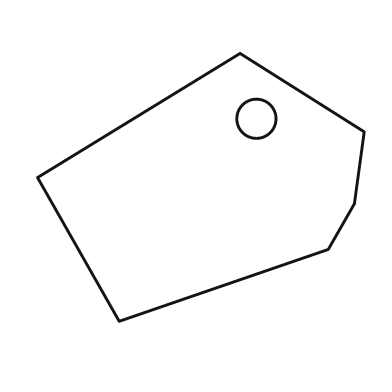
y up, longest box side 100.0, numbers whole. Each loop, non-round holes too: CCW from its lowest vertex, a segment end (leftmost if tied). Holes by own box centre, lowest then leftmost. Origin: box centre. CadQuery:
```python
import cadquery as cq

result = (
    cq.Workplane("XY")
    .moveTo(-25.0, -41.0)
    .lineTo(39.0, -19.0)
    .lineTo(47.0, -5.0)
    .lineTo(50.0, 17.0)
    .lineTo(12.0, 41.0)
    .lineTo(-50.0, 3.0)
    .close()
    .moveTo(17.0, 21.0)
    .circle(6.0)
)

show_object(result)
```